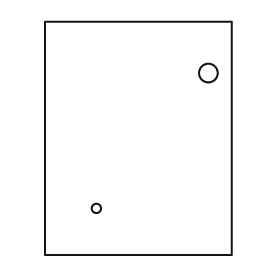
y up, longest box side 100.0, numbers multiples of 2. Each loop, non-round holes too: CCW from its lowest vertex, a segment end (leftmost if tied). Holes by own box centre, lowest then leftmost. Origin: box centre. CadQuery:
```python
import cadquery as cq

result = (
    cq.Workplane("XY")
    .moveTo(-40.0, -50.0)
    .lineTo(40.0, -50.0)
    .lineTo(40.0, 50.0)
    .lineTo(-40.0, 50.0)
    .close()
    .moveTo(-18.0, -30.0)
    .circle(2.0)
    .moveTo(30.0, 28.0)
    .circle(4.0)
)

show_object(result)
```